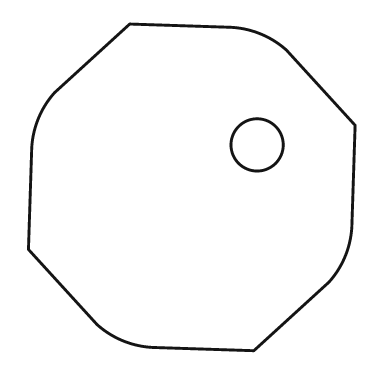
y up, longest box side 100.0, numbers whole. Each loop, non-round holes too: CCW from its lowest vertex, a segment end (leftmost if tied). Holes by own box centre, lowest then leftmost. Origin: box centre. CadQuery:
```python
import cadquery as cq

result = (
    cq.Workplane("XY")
    .moveTo(19.0, -50.0)
    .lineTo(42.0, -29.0)
    .threePointArc((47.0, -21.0), (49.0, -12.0))
    .lineTo(50.0, 19.0)
    .lineTo(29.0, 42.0)
    .threePointArc((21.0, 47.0), (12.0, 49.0))
    .lineTo(-19.0, 50.0)
    .lineTo(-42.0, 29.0)
    .threePointArc((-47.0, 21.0), (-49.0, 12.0))
    .lineTo(-50.0, -19.0)
    .lineTo(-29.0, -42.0)
    .threePointArc((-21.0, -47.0), (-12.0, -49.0))
    .close()
    .moveTo(20.0, 13.0)
    .circle(8.0)
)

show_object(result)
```